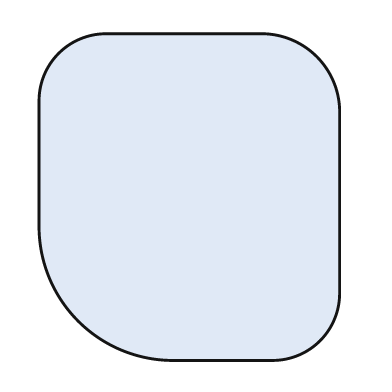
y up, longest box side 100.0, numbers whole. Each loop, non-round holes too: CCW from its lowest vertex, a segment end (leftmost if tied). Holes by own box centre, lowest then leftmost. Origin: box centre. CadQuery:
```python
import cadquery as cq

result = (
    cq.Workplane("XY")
    .moveTo(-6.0, -50.0)
    .lineTo(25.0, -50.0)
    .threePointArc((40.0, -44.0), (46.0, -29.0))
    .lineTo(46.0, 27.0)
    .threePointArc((39.0, 43.0), (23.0, 50.0))
    .lineTo(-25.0, 50.0)
    .threePointArc((-40.0, 44.0), (-46.0, 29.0))
    .lineTo(-46.0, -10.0)
    .threePointArc((-34.0, -38.0), (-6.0, -50.0))
    .close()
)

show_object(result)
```